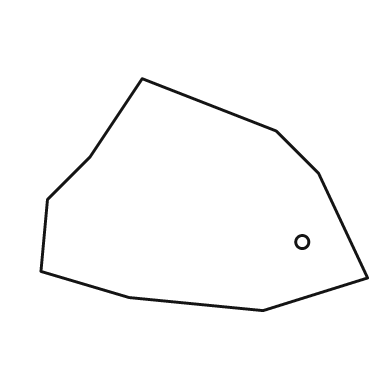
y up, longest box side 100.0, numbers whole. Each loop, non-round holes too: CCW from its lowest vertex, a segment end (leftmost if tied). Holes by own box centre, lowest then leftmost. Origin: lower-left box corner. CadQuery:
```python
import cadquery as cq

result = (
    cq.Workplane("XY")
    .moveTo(68.0, 0.0)
    .lineTo(100.0, 10.0)
    .lineTo(85.0, 42.0)
    .lineTo(72.0, 55.0)
    .lineTo(31.0, 71.0)
    .lineTo(15.0, 47.0)
    .lineTo(2.0, 34.0)
    .lineTo(0.0, 12.0)
    .lineTo(27.0, 4.0)
    .close()
    .moveTo(80.0, 21.0)
    .circle(2.0)
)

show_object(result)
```